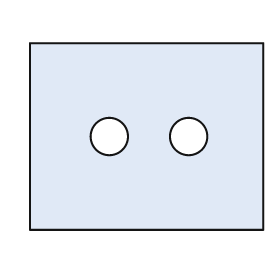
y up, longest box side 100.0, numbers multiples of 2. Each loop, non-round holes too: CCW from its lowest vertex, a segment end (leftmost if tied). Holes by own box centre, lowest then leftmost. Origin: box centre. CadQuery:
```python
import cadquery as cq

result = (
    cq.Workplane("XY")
    .moveTo(-50.0, -40.0)
    .lineTo(50.0, -40.0)
    .lineTo(50.0, 40.0)
    .lineTo(-50.0, 40.0)
    .close()
    .moveTo(-16.0, 0.0)
    .circle(8.0)
    .moveTo(18.0, 0.0)
    .circle(8.0)
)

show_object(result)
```